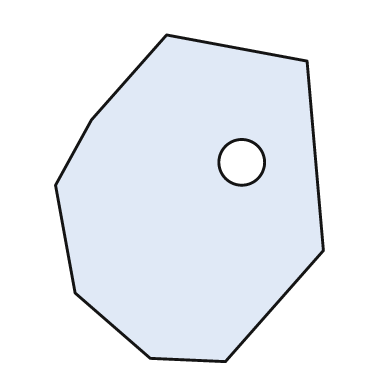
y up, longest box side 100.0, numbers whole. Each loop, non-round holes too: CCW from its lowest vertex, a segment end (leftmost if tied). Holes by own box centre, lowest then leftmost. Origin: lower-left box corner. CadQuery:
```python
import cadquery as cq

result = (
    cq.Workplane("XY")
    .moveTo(52.0, 0.0)
    .lineTo(82.0, 34.0)
    .lineTo(77.0, 92.0)
    .lineTo(34.0, 100.0)
    .lineTo(11.0, 74.0)
    .lineTo(0.0, 54.0)
    .lineTo(6.0, 21.0)
    .lineTo(29.0, 1.0)
    .close()
    .moveTo(57.0, 61.0)
    .circle(7.0)
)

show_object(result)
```